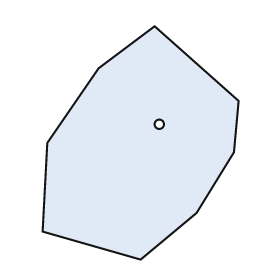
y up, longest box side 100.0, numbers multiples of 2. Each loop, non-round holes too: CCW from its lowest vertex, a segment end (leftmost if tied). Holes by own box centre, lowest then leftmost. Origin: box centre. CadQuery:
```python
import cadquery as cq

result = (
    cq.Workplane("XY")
    .moveTo(0.0, -50.0)
    .lineTo(24.0, -30.0)
    .lineTo(40.0, -4.0)
    .lineTo(42.0, 18.0)
    .lineTo(6.0, 50.0)
    .lineTo(-18.0, 32.0)
    .lineTo(-40.0, 0.0)
    .lineTo(-42.0, -38.0)
    .close()
    .moveTo(8.0, 8.0)
    .circle(2.0)
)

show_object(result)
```